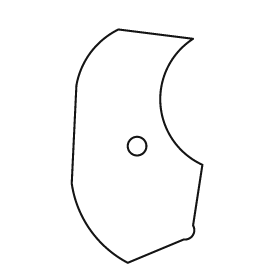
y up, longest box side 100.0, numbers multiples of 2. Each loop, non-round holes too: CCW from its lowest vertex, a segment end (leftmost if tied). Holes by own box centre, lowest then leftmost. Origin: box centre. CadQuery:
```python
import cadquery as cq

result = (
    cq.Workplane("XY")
    .moveTo(-4.0, -50.0)
    .lineTo(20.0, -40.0)
    .threePointArc((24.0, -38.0), (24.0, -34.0))
    .lineTo(28.0, -8.0)
    .threePointArc((10.0, 18.0), (24.0, 46.0))
    .lineTo(-8.0, 50.0)
    .threePointArc((-20.0, 40.0), (-26.0, 26.0))
    .lineTo(-28.0, -16.0)
    .threePointArc((-20.0, -36.0), (-4.0, -50.0))
    .close()
    .moveTo(0.0, 0.0)
    .circle(4.0)
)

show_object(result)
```